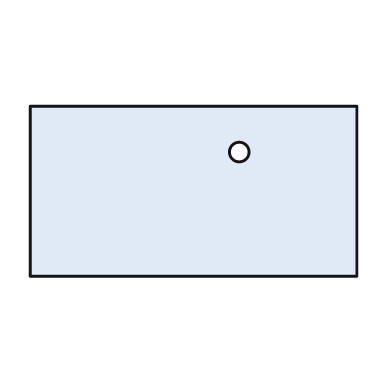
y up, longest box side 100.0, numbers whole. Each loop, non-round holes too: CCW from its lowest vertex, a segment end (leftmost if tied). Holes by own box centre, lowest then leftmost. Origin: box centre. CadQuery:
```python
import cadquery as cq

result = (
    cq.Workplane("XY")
    .moveTo(-50.0, -26.0)
    .lineTo(50.0, -26.0)
    .lineTo(50.0, 26.0)
    .lineTo(-50.0, 26.0)
    .close()
    .moveTo(14.0, 12.0)
    .circle(3.0)
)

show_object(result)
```